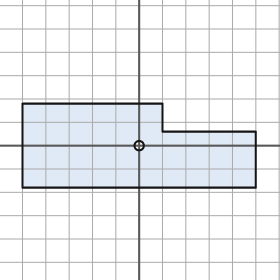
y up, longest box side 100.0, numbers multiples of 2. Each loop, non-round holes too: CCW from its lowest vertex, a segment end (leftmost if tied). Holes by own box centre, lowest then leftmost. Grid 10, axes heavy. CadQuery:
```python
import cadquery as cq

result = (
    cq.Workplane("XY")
    .moveTo(-50.0, -18.0)
    .lineTo(50.0, -18.0)
    .lineTo(50.0, 6.0)
    .lineTo(10.0, 6.0)
    .lineTo(10.0, 18.0)
    .lineTo(-50.0, 18.0)
    .close()
    .moveTo(0.0, 0.0)
    .circle(2.0)
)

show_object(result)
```